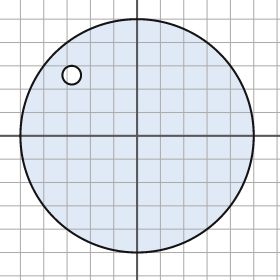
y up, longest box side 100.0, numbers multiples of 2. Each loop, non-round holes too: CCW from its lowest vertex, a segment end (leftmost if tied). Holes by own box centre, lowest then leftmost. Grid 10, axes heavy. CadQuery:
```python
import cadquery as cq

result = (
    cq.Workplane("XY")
    .moveTo(0.0, 0.0)
    .circle(50.0)
    .moveTo(-28.0, 26.0)
    .circle(4.0)
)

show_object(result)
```